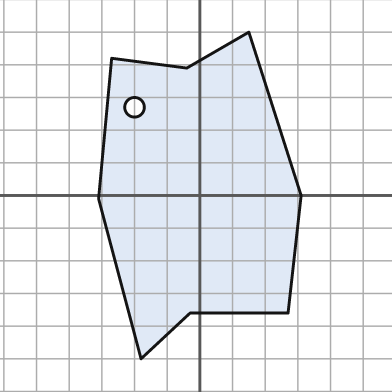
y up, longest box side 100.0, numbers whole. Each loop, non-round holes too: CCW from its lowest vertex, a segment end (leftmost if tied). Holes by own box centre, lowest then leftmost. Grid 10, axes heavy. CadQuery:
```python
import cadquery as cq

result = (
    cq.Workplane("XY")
    .moveTo(-18.0, -50.0)
    .lineTo(-3.0, -36.0)
    .lineTo(27.0, -36.0)
    .lineTo(31.0, 0.0)
    .lineTo(15.0, 50.0)
    .lineTo(-4.0, 39.0)
    .lineTo(-27.0, 42.0)
    .lineTo(-31.0, -1.0)
    .close()
    .moveTo(-20.0, 27.0)
    .circle(3.0)
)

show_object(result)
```